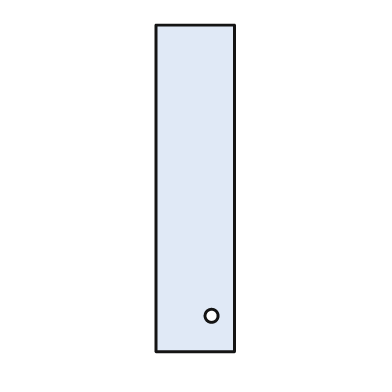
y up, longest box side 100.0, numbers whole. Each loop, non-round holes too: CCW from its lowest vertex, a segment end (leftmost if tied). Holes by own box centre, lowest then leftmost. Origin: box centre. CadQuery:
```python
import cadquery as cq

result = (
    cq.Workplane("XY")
    .moveTo(-12.0, -50.0)
    .lineTo(12.0, -50.0)
    .lineTo(12.0, 50.0)
    .lineTo(-12.0, 50.0)
    .close()
    .moveTo(5.0, -39.0)
    .circle(2.0)
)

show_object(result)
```